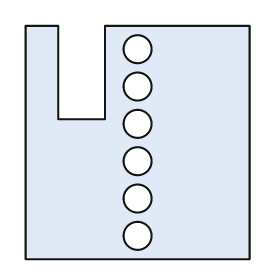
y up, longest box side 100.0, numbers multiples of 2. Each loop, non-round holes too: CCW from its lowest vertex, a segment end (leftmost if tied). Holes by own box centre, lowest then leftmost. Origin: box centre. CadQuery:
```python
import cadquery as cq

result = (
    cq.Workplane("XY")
    .moveTo(-48.0, -50.0)
    .lineTo(48.0, -50.0)
    .lineTo(48.0, 50.0)
    .lineTo(-14.0, 50.0)
    .lineTo(-14.0, 10.0)
    .lineTo(-34.0, 10.0)
    .lineTo(-34.0, 50.0)
    .lineTo(-48.0, 50.0)
    .close()
    .moveTo(0.0, -40.0)
    .circle(6.0)
    .moveTo(0.0, -24.0)
    .circle(6.0)
    .moveTo(0.0, -8.0)
    .circle(6.0)
    .moveTo(0.0, 8.0)
    .circle(6.0)
    .moveTo(0.0, 24.0)
    .circle(6.0)
    .moveTo(0.0, 40.0)
    .circle(6.0)
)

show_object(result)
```